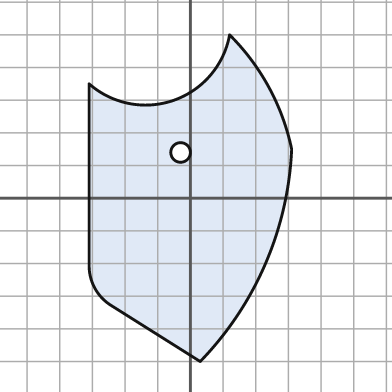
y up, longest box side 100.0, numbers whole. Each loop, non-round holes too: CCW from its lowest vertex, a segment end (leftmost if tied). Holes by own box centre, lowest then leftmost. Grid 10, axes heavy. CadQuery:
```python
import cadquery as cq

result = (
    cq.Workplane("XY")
    .moveTo(3.0, -50.0)
    .threePointArc((23.0, -20.0), (31.0, 15.0))
    .threePointArc((24.0, 34.0), (12.0, 50.0))
    .threePointArc((-5.0, 30.0), (-31.0, 35.0))
    .lineTo(-31.0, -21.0)
    .threePointArc((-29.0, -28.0), (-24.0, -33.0))
    .close()
    .moveTo(-3.0, 14.0)
    .circle(3.0)
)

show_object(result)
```